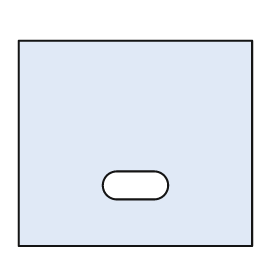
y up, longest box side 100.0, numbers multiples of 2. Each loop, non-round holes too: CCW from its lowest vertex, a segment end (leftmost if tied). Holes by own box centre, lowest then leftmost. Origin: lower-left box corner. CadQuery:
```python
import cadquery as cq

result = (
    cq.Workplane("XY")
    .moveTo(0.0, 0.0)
    .lineTo(100.0, 0.0)
    .lineTo(100.0, 88.0)
    .lineTo(0.0, 88.0)
    .close()
    .moveTo(42.0, 20.0)
    .lineTo(58.0, 20.0)
    .threePointArc((64.0, 26.0), (58.0, 32.0))
    .lineTo(42.0, 32.0)
    .threePointArc((36.0, 26.0), (42.0, 20.0))
    .close()
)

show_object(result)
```